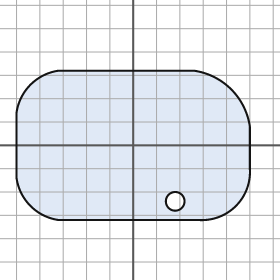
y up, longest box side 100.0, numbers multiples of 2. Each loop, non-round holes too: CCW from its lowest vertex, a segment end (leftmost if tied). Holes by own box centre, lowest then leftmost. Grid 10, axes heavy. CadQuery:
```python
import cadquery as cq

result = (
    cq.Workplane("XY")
    .moveTo(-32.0, -32.0)
    .lineTo(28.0, -32.0)
    .threePointArc((44.0, -26.0), (50.0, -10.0))
    .lineTo(50.0, 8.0)
    .threePointArc((42.0, 24.0), (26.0, 32.0))
    .lineTo(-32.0, 32.0)
    .threePointArc((-44.0, 26.0), (-50.0, 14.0))
    .lineTo(-50.0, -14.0)
    .threePointArc((-44.0, -26.0), (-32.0, -32.0))
    .close()
    .moveTo(18.0, -24.0)
    .circle(4.0)
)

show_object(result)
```